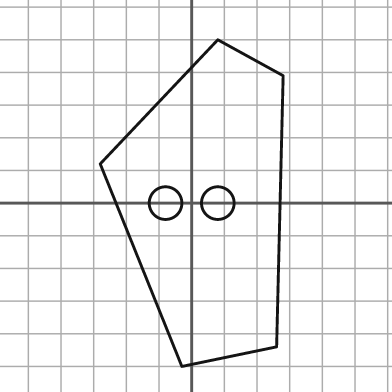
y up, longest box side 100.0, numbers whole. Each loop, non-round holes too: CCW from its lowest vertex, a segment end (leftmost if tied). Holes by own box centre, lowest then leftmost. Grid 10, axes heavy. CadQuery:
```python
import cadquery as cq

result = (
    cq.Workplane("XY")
    .moveTo(-3.0, -50.0)
    .lineTo(26.0, -44.0)
    .lineTo(28.0, 39.0)
    .lineTo(8.0, 50.0)
    .lineTo(-28.0, 12.0)
    .close()
    .moveTo(-8.0, 0.0)
    .circle(5.0)
    .moveTo(8.0, 0.0)
    .circle(5.0)
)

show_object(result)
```